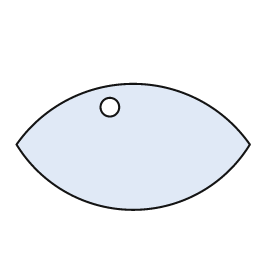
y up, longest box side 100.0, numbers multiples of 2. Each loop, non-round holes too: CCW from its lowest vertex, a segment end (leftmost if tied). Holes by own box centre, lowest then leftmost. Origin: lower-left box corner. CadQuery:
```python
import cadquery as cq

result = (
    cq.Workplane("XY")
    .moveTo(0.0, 28.0)
    .threePointArc((50.0, 0.0), (100.0, 28.0))
    .threePointArc((50.0, 54.0), (0.0, 28.0))
    .close()
    .moveTo(40.0, 44.0)
    .circle(4.0)
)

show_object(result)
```